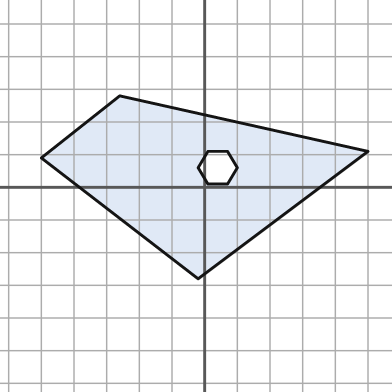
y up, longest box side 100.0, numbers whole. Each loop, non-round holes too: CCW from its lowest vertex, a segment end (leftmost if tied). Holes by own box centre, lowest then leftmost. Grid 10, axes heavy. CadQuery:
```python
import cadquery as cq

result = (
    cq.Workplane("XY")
    .moveTo(-2.0, -28.0)
    .lineTo(50.0, 11.0)
    .lineTo(-26.0, 28.0)
    .lineTo(-50.0, 9.0)
    .close()
    .moveTo(1.0, 1.0)
    .lineTo(7.0, 1.0)
    .lineTo(10.0, 6.0)
    .lineTo(7.0, 11.0)
    .lineTo(1.0, 11.0)
    .lineTo(-2.0, 6.0)
    .close()
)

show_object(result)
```